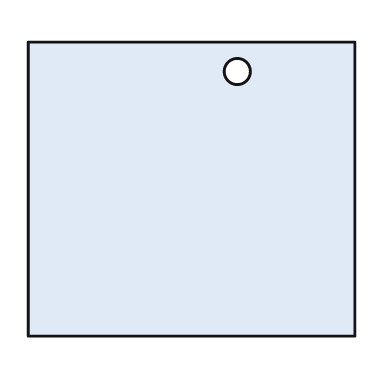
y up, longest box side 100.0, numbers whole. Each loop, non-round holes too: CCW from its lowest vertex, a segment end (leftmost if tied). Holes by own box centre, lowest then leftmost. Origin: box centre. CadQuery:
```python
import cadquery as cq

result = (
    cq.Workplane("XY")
    .moveTo(-50.0, -45.0)
    .lineTo(50.0, -45.0)
    .lineTo(50.0, 45.0)
    .lineTo(-50.0, 45.0)
    .close()
    .moveTo(14.0, 36.0)
    .circle(4.0)
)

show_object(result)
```